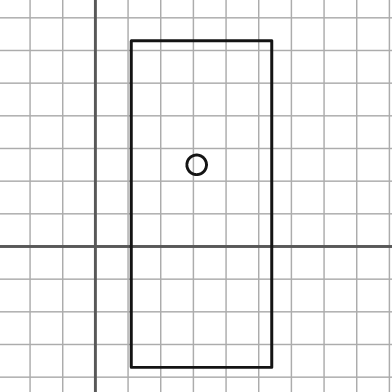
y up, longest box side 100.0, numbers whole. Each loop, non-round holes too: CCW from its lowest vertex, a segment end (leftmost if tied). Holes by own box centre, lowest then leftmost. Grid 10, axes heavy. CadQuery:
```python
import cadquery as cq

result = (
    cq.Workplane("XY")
    .moveTo(11.0, -37.0)
    .lineTo(54.0, -37.0)
    .lineTo(54.0, 63.0)
    .lineTo(11.0, 63.0)
    .close()
    .moveTo(31.0, 25.0)
    .circle(3.0)
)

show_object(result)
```